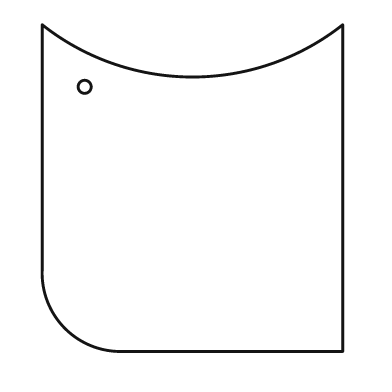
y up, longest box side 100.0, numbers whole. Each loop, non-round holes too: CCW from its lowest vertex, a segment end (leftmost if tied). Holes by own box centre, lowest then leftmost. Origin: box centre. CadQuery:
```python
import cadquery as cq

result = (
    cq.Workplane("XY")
    .moveTo(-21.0, -50.0)
    .lineTo(46.0, -50.0)
    .lineTo(46.0, 50.0)
    .threePointArc((0.0, 34.0), (-46.0, 50.0))
    .lineTo(-46.0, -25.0)
    .threePointArc((-39.0, -43.0), (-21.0, -50.0))
    .close()
    .moveTo(-33.0, 31.0)
    .circle(2.0)
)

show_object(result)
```